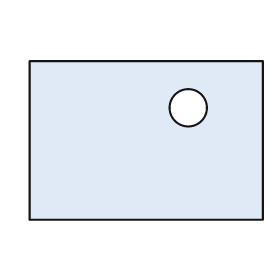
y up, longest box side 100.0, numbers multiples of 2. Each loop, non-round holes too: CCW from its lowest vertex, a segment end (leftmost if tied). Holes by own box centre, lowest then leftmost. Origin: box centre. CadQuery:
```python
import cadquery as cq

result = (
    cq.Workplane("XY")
    .moveTo(-50.0, -34.0)
    .lineTo(50.0, -34.0)
    .lineTo(50.0, 34.0)
    .lineTo(-50.0, 34.0)
    .close()
    .moveTo(18.0, 14.0)
    .circle(8.0)
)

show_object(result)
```